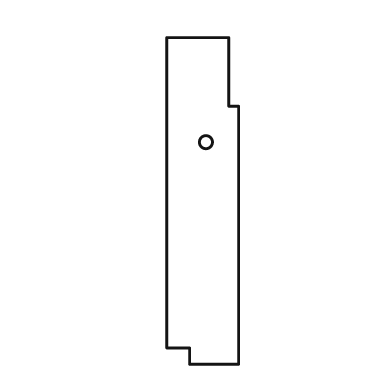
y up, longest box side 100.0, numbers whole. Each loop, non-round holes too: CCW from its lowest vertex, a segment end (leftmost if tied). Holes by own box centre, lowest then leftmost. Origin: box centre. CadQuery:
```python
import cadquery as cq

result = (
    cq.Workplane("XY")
    .moveTo(-4.0, -50.0)
    .lineTo(11.0, -50.0)
    .lineTo(11.0, 29.0)
    .lineTo(8.0, 29.0)
    .lineTo(8.0, 50.0)
    .lineTo(-11.0, 50.0)
    .lineTo(-11.0, -45.0)
    .lineTo(-4.0, -45.0)
    .close()
    .moveTo(1.0, 18.0)
    .circle(2.0)
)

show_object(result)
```